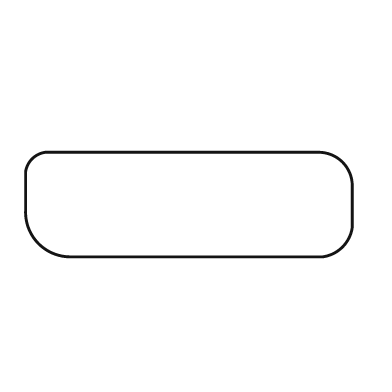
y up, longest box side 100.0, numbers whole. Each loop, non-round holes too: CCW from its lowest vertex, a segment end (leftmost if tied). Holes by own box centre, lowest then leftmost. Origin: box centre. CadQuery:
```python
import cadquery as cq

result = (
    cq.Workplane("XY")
    .moveTo(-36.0, -16.0)
    .lineTo(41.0, -16.0)
    .threePointArc((47.0, -13.0), (50.0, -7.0))
    .lineTo(50.0, 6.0)
    .threePointArc((47.0, 13.0), (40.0, 16.0))
    .lineTo(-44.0, 16.0)
    .threePointArc((-48.0, 14.0), (-50.0, 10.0))
    .lineTo(-50.0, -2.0)
    .threePointArc((-46.0, -12.0), (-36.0, -16.0))
    .close()
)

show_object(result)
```